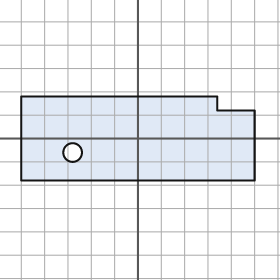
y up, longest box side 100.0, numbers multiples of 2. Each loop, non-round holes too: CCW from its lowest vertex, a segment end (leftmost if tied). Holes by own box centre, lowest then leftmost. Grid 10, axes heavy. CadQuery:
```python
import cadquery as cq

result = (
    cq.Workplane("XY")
    .moveTo(-50.0, -18.0)
    .lineTo(50.0, -18.0)
    .lineTo(50.0, 12.0)
    .lineTo(34.0, 12.0)
    .lineTo(34.0, 18.0)
    .lineTo(-50.0, 18.0)
    .close()
    .moveTo(-28.0, -6.0)
    .circle(4.0)
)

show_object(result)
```